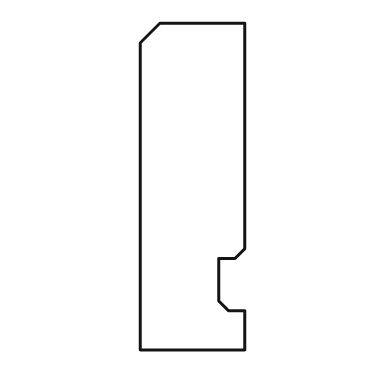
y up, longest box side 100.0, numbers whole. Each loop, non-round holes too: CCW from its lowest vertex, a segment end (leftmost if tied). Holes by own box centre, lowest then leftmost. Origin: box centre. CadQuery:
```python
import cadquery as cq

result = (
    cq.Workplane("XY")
    .moveTo(-16.0, -50.0)
    .lineTo(16.0, -50.0)
    .lineTo(16.0, -38.0)
    .lineTo(11.0, -38.0)
    .lineTo(8.0, -35.0)
    .lineTo(8.0, -22.0)
    .lineTo(13.0, -22.0)
    .lineTo(16.0, -19.0)
    .lineTo(16.0, 50.0)
    .lineTo(-10.0, 50.0)
    .lineTo(-16.0, 44.0)
    .close()
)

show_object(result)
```